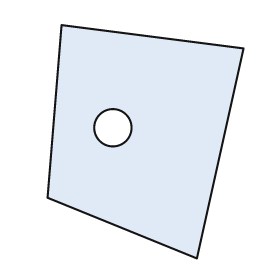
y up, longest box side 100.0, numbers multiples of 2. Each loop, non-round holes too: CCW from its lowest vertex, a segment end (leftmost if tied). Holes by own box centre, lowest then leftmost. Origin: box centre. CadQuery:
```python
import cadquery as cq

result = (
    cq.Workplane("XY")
    .moveTo(22.0, -50.0)
    .lineTo(42.0, 40.0)
    .lineTo(-36.0, 50.0)
    .lineTo(-42.0, -24.0)
    .close()
    .moveTo(-14.0, 6.0)
    .circle(8.0)
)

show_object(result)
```